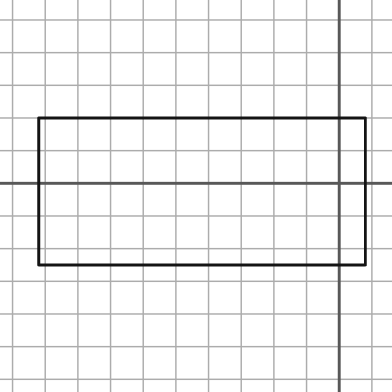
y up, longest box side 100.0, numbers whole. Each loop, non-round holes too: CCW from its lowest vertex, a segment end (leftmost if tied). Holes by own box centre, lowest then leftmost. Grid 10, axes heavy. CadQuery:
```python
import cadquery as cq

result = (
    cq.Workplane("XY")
    .moveTo(-92.0, -25.0)
    .lineTo(8.0, -25.0)
    .lineTo(8.0, 20.0)
    .lineTo(-92.0, 20.0)
    .close()
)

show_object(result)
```